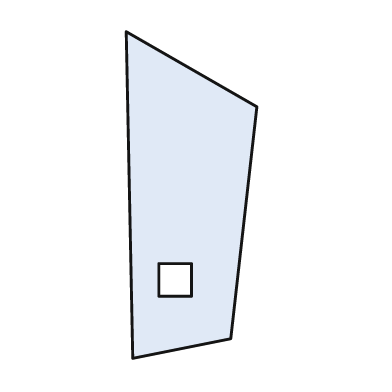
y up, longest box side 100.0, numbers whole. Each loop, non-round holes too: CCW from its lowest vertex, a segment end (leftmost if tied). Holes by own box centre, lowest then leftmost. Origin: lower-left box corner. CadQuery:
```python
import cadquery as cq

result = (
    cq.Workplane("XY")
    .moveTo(2.0, 0.0)
    .lineTo(32.0, 6.0)
    .lineTo(40.0, 77.0)
    .lineTo(0.0, 100.0)
    .close()
    .moveTo(10.0, 19.0)
    .lineTo(20.0, 19.0)
    .lineTo(20.0, 29.0)
    .lineTo(10.0, 29.0)
    .close()
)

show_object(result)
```